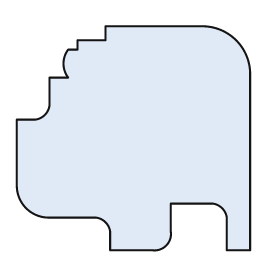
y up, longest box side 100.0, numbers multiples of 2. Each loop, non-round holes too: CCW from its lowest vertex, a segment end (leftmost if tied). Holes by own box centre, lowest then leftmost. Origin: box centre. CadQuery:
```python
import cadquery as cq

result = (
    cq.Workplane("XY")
    .moveTo(-10.0, -48.0)
    .lineTo(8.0, -48.0)
    .threePointArc((14.0, -46.0), (16.0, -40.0))
    .lineTo(16.0, -28.0)
    .lineTo(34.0, -28.0)
    .threePointArc((38.0, -30.0), (40.0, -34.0))
    .lineTo(40.0, -48.0)
    .lineTo(50.0, -48.0)
    .lineTo(50.0, 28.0)
    .threePointArc((44.0, 42.0), (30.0, 48.0))
    .lineTo(-12.0, 48.0)
    .lineTo(-12.0, 42.0)
    .lineTo(-24.0, 42.0)
    .lineTo(-24.0, 38.0)
    .lineTo(-28.0, 38.0)
    .threePointArc((-30.0, 32.0), (-28.0, 26.0))
    .lineTo(-36.0, 26.0)
    .lineTo(-36.0, 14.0)
    .threePointArc((-38.0, 10.0), (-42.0, 8.0))
    .lineTo(-50.0, 8.0)
    .lineTo(-50.0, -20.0)
    .threePointArc((-46.0, -30.0), (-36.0, -34.0))
    .lineTo(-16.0, -34.0)
    .threePointArc((-12.0, -36.0), (-10.0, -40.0))
    .close()
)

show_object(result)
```